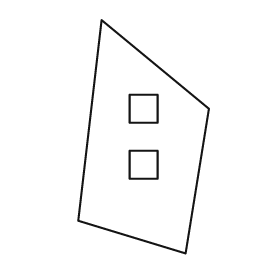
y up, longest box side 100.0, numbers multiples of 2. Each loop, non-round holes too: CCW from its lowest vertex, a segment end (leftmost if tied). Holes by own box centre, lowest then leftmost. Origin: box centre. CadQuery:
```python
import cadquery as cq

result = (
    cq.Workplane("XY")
    .moveTo(18.0, -50.0)
    .lineTo(28.0, 12.0)
    .lineTo(-18.0, 50.0)
    .lineTo(-28.0, -36.0)
    .close()
    .moveTo(-6.0, -18.0)
    .lineTo(6.0, -18.0)
    .lineTo(6.0, -6.0)
    .lineTo(-6.0, -6.0)
    .close()
    .moveTo(-6.0, 6.0)
    .lineTo(6.0, 6.0)
    .lineTo(6.0, 18.0)
    .lineTo(-6.0, 18.0)
    .close()
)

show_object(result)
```